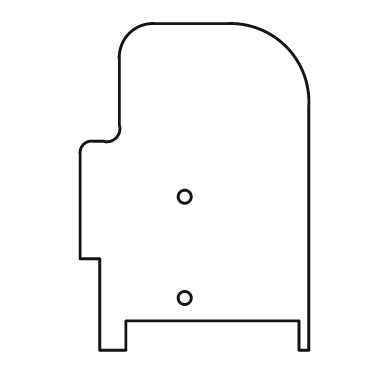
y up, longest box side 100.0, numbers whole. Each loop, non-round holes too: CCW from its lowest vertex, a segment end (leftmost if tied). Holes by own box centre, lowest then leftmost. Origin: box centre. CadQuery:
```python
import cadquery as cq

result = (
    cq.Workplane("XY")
    .moveTo(-29.0, -50.0)
    .lineTo(-21.0, -50.0)
    .lineTo(-21.0, -41.0)
    .lineTo(32.0, -41.0)
    .lineTo(32.0, -50.0)
    .lineTo(35.0, -50.0)
    .lineTo(35.0, 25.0)
    .threePointArc((28.0, 43.0), (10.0, 50.0))
    .lineTo(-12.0, 50.0)
    .threePointArc((-20.0, 47.0), (-23.0, 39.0))
    .lineTo(-23.0, 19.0)
    .threePointArc((-24.0, 15.0), (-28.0, 14.0))
    .lineTo(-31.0, 14.0)
    .threePointArc((-34.0, 13.0), (-35.0, 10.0))
    .lineTo(-35.0, -22.0)
    .lineTo(-29.0, -22.0)
    .close()
    .moveTo(-3.0, -34.0)
    .circle(2.0)
    .moveTo(-3.0, -3.0)
    .circle(2.0)
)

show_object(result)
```